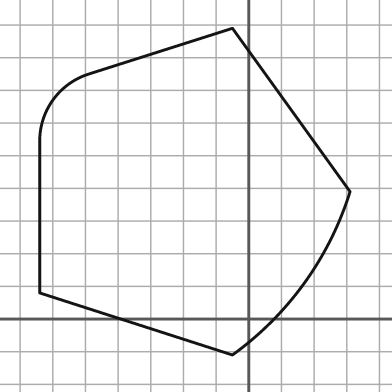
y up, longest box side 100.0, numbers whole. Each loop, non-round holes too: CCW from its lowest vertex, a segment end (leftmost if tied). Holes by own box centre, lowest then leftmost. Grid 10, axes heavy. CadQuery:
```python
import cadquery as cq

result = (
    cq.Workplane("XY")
    .moveTo(-5.0, -11.0)
    .threePointArc((17.0, 11.0), (31.0, 39.0))
    .lineTo(-5.0, 89.0)
    .lineTo(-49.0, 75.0)
    .threePointArc((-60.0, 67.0), (-64.0, 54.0))
    .lineTo(-64.0, 8.0)
    .close()
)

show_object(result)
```